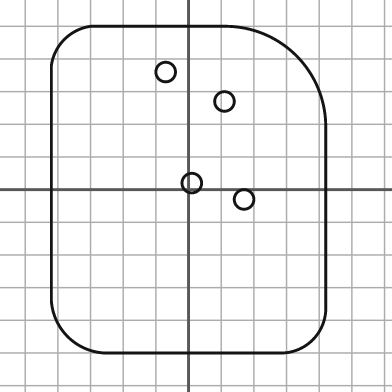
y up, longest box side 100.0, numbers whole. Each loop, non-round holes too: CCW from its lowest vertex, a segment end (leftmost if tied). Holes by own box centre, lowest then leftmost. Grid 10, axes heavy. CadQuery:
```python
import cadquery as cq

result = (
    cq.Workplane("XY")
    .moveTo(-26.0, -50.0)
    .lineTo(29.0, -50.0)
    .threePointArc((38.0, -46.0), (42.0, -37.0))
    .lineTo(42.0, 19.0)
    .threePointArc((33.0, 41.0), (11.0, 50.0))
    .lineTo(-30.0, 50.0)
    .threePointArc((-38.0, 46.0), (-42.0, 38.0))
    .lineTo(-42.0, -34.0)
    .threePointArc((-37.0, -45.0), (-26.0, -50.0))
    .close()
    .moveTo(17.0, -3.0)
    .circle(3.0)
    .moveTo(1.0, 2.0)
    .circle(3.0)
    .moveTo(11.0, 27.0)
    .circle(3.0)
    .moveTo(-7.0, 36.0)
    .circle(3.0)
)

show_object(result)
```